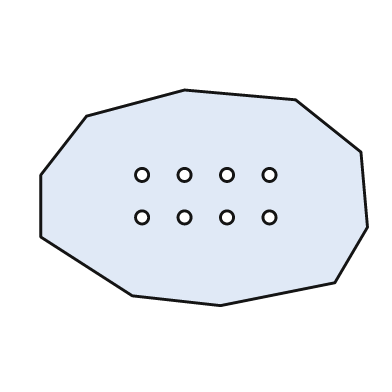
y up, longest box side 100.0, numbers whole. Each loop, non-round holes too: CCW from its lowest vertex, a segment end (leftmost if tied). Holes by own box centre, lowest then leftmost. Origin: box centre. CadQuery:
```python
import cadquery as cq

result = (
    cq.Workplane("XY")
    .moveTo(5.0, -33.0)
    .lineTo(40.0, -26.0)
    .lineTo(50.0, -9.0)
    .lineTo(48.0, 14.0)
    .lineTo(28.0, 30.0)
    .lineTo(-6.0, 33.0)
    .lineTo(-36.0, 25.0)
    .lineTo(-50.0, 7.0)
    .lineTo(-50.0, -12.0)
    .lineTo(-22.0, -30.0)
    .close()
    .moveTo(-19.0, -6.0)
    .circle(2.0)
    .moveTo(-6.0, -6.0)
    .circle(2.0)
    .moveTo(7.0, -6.0)
    .circle(2.0)
    .moveTo(20.0, -6.0)
    .circle(2.0)
    .moveTo(-19.0, 7.0)
    .circle(2.0)
    .moveTo(-6.0, 7.0)
    .circle(2.0)
    .moveTo(7.0, 7.0)
    .circle(2.0)
    .moveTo(20.0, 7.0)
    .circle(2.0)
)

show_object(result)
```